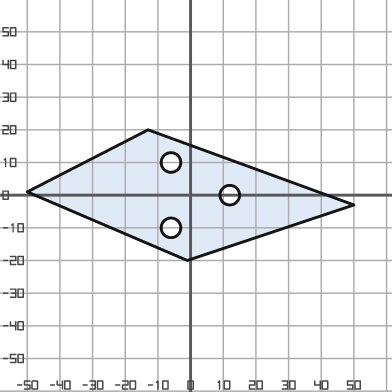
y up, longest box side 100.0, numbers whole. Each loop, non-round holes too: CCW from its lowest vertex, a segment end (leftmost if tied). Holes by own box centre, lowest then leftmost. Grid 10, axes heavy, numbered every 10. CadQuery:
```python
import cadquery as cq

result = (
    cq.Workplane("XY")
    .moveTo(-1.0, -20.0)
    .lineTo(50.0, -3.0)
    .lineTo(-13.0, 20.0)
    .lineTo(-50.0, 1.0)
    .close()
    .moveTo(-6.0, -10.0)
    .circle(3.0)
    .moveTo(12.0, 0.0)
    .circle(3.0)
    .moveTo(-6.0, 10.0)
    .circle(3.0)
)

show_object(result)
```